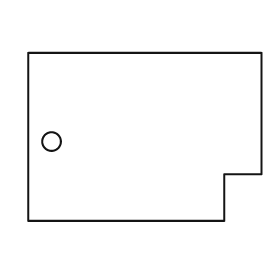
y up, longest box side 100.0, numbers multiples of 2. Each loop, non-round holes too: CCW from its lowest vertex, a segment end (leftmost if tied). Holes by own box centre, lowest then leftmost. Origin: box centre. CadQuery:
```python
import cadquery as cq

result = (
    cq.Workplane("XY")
    .moveTo(-50.0, -36.0)
    .lineTo(34.0, -36.0)
    .lineTo(34.0, -16.0)
    .lineTo(50.0, -16.0)
    .lineTo(50.0, 36.0)
    .lineTo(-50.0, 36.0)
    .close()
    .moveTo(-40.0, -2.0)
    .circle(4.0)
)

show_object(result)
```